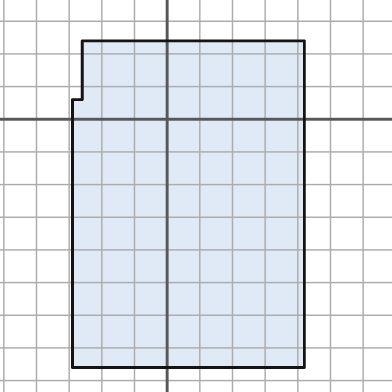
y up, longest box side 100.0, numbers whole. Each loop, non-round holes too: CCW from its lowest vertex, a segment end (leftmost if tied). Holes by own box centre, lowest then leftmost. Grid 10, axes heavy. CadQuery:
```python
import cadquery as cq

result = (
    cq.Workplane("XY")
    .moveTo(-29.0, -76.0)
    .lineTo(42.0, -76.0)
    .lineTo(42.0, 24.0)
    .lineTo(-26.0, 24.0)
    .lineTo(-26.0, 6.0)
    .lineTo(-29.0, 6.0)
    .close()
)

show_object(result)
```